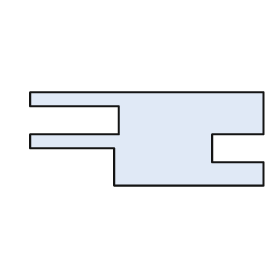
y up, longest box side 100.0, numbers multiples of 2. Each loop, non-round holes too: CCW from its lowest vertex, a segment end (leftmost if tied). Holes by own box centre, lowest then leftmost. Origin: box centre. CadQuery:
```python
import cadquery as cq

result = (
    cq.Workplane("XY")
    .moveTo(-14.0, -20.0)
    .lineTo(50.0, -20.0)
    .lineTo(50.0, -10.0)
    .lineTo(28.0, -10.0)
    .lineTo(28.0, 2.0)
    .lineTo(50.0, 2.0)
    .lineTo(50.0, 20.0)
    .lineTo(-50.0, 20.0)
    .lineTo(-50.0, 14.0)
    .lineTo(-12.0, 14.0)
    .lineTo(-12.0, 2.0)
    .lineTo(-50.0, 2.0)
    .lineTo(-50.0, -4.0)
    .lineTo(-14.0, -4.0)
    .close()
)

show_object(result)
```